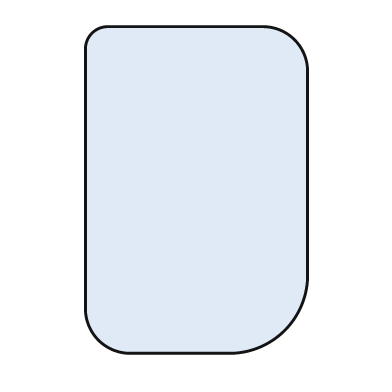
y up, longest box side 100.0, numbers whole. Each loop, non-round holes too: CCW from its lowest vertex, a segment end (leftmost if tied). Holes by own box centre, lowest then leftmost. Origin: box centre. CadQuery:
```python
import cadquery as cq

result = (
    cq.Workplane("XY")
    .moveTo(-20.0, -50.0)
    .lineTo(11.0, -50.0)
    .threePointArc((27.0, -43.0), (34.0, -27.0))
    .lineTo(34.0, 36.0)
    .threePointArc((30.0, 46.0), (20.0, 50.0))
    .lineTo(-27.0, 50.0)
    .threePointArc((-32.0, 48.0), (-34.0, 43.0))
    .lineTo(-34.0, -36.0)
    .threePointArc((-30.0, -46.0), (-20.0, -50.0))
    .close()
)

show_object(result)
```